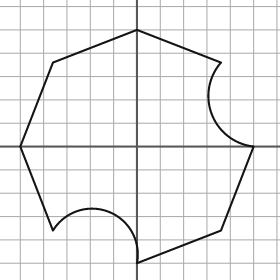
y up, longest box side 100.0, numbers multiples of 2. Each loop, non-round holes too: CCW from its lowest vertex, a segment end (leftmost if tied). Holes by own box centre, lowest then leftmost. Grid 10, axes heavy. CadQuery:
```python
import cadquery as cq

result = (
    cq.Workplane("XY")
    .moveTo(0.0, -50.0)
    .lineTo(36.0, -36.0)
    .lineTo(50.0, 0.0)
    .threePointArc((32.0, 14.0), (36.0, 36.0))
    .lineTo(0.0, 50.0)
    .lineTo(-36.0, 36.0)
    .lineTo(-50.0, 0.0)
    .lineTo(-36.0, -36.0)
    .threePointArc((-12.0, -28.0), (0.0, -50.0))
    .close()
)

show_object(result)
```